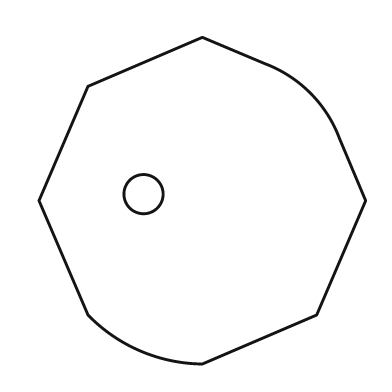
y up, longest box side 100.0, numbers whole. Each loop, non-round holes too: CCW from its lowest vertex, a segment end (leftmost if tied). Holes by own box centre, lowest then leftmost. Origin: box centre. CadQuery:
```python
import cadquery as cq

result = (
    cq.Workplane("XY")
    .moveTo(0.0, -50.0)
    .lineTo(35.0, -35.0)
    .lineTo(50.0, 0.0)
    .lineTo(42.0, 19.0)
    .threePointArc((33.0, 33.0), (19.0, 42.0))
    .lineTo(0.0, 50.0)
    .lineTo(-35.0, 35.0)
    .lineTo(-50.0, 0.0)
    .lineTo(-35.0, -35.0)
    .threePointArc((-19.0, -46.0), (0.0, -50.0))
    .close()
    .moveTo(-18.0, 2.0)
    .circle(6.0)
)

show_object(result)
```